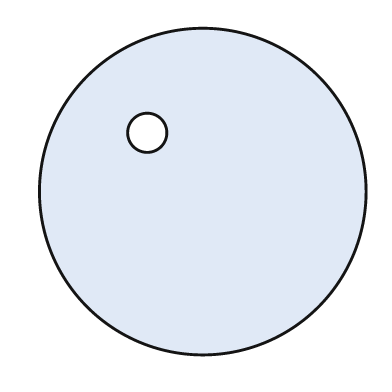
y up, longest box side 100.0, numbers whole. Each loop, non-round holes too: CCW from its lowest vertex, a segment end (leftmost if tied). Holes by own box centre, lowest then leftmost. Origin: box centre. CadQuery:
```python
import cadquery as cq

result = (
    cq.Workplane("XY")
    .moveTo(0.0, 0.0)
    .circle(50.0)
    .moveTo(-17.0, 18.0)
    .circle(6.0)
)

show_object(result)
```